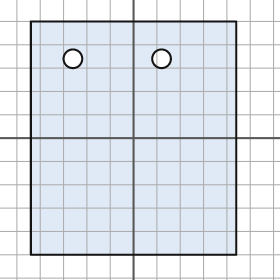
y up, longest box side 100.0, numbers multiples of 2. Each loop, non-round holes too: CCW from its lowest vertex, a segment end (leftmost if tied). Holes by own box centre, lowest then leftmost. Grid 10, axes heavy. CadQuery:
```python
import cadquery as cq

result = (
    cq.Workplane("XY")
    .moveTo(-44.0, -50.0)
    .lineTo(44.0, -50.0)
    .lineTo(44.0, 50.0)
    .lineTo(-44.0, 50.0)
    .close()
    .moveTo(-26.0, 34.0)
    .circle(4.0)
    .moveTo(12.0, 34.0)
    .circle(4.0)
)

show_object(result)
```